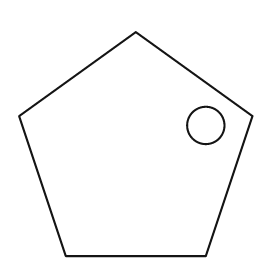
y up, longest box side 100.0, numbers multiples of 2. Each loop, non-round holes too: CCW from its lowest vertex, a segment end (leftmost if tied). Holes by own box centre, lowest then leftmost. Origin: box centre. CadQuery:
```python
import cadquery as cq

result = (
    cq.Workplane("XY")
    .moveTo(-30.0, -48.0)
    .lineTo(30.0, -48.0)
    .lineTo(50.0, 12.0)
    .lineTo(0.0, 48.0)
    .lineTo(-50.0, 12.0)
    .close()
    .moveTo(30.0, 8.0)
    .circle(8.0)
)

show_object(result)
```